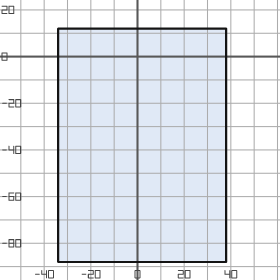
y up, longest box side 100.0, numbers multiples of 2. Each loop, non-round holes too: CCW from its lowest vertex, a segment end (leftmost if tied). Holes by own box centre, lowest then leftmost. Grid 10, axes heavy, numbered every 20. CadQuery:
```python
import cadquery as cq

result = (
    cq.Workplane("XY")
    .moveTo(-34.0, -88.0)
    .lineTo(38.0, -88.0)
    .lineTo(38.0, 12.0)
    .lineTo(-34.0, 12.0)
    .close()
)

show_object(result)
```